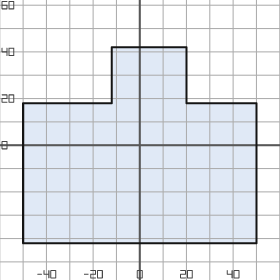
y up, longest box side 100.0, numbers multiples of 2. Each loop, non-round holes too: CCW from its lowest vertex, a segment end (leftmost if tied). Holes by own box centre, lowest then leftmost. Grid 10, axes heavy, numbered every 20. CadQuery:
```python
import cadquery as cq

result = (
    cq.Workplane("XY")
    .moveTo(-50.0, -42.0)
    .lineTo(50.0, -42.0)
    .lineTo(50.0, 18.0)
    .lineTo(20.0, 18.0)
    .lineTo(20.0, 42.0)
    .lineTo(-12.0, 42.0)
    .lineTo(-12.0, 18.0)
    .lineTo(-50.0, 18.0)
    .close()
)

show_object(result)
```